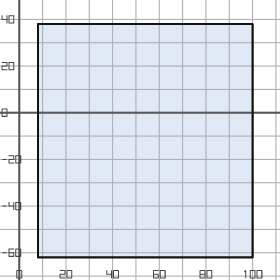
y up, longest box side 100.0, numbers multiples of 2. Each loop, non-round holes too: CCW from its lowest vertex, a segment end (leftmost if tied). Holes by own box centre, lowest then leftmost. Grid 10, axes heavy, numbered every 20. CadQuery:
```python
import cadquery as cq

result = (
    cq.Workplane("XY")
    .moveTo(8.0, -62.0)
    .lineTo(100.0, -62.0)
    .lineTo(100.0, 38.0)
    .lineTo(8.0, 38.0)
    .close()
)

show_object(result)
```